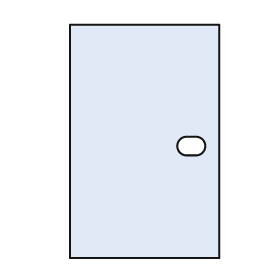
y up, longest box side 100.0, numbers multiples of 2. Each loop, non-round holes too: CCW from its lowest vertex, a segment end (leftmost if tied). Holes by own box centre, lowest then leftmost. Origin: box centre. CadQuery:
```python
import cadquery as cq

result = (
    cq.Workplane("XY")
    .moveTo(-32.0, -50.0)
    .lineTo(32.0, -50.0)
    .lineTo(32.0, 50.0)
    .lineTo(-32.0, 50.0)
    .close()
    .moveTo(18.0, -6.0)
    .lineTo(22.0, -6.0)
    .threePointArc((26.0, -2.0), (22.0, 2.0))
    .lineTo(18.0, 2.0)
    .threePointArc((14.0, -2.0), (18.0, -6.0))
    .close()
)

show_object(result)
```